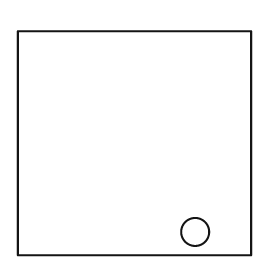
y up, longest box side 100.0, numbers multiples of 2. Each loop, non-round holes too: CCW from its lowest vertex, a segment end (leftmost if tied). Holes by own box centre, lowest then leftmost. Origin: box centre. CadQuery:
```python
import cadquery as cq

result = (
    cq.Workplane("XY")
    .moveTo(-50.0, -48.0)
    .lineTo(50.0, -48.0)
    .lineTo(50.0, 48.0)
    .lineTo(-50.0, 48.0)
    .close()
    .moveTo(26.0, -38.0)
    .circle(6.0)
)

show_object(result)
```